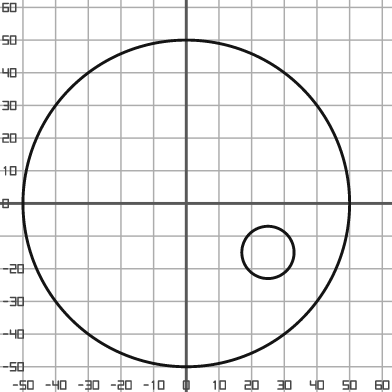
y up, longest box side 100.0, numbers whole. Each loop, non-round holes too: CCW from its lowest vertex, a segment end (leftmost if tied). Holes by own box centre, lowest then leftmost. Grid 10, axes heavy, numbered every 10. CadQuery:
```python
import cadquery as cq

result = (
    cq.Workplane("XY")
    .moveTo(0.0, 0.0)
    .circle(50.0)
    .moveTo(25.0, -15.0)
    .circle(8.0)
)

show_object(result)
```